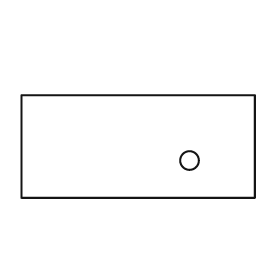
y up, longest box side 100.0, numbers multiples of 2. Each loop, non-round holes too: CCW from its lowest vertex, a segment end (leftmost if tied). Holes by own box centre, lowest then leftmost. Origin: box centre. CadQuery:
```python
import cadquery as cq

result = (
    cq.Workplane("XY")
    .moveTo(-50.0, -22.0)
    .lineTo(50.0, -22.0)
    .lineTo(50.0, 22.0)
    .lineTo(-50.0, 22.0)
    .close()
    .moveTo(22.0, -6.0)
    .circle(4.0)
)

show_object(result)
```